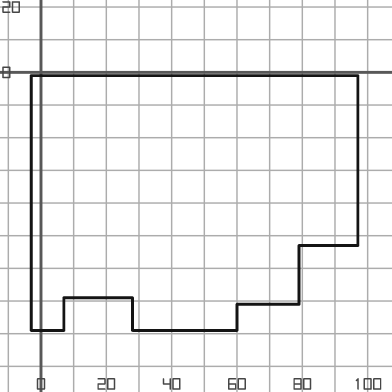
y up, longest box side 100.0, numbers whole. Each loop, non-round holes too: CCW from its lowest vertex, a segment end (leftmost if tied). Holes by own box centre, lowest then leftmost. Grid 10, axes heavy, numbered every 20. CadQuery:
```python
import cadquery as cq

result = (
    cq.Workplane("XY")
    .moveTo(-3.0, -79.0)
    .lineTo(7.0, -79.0)
    .lineTo(7.0, -69.0)
    .lineTo(28.0, -69.0)
    .lineTo(28.0, -79.0)
    .lineTo(60.0, -79.0)
    .lineTo(60.0, -71.0)
    .lineTo(79.0, -71.0)
    .lineTo(79.0, -53.0)
    .lineTo(97.0, -53.0)
    .lineTo(97.0, -1.0)
    .lineTo(-3.0, -1.0)
    .close()
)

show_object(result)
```